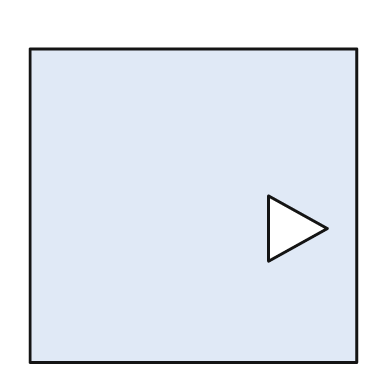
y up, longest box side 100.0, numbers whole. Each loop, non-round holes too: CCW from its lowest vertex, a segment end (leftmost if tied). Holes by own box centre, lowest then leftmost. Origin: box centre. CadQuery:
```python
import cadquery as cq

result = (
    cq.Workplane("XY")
    .moveTo(-50.0, -48.0)
    .lineTo(50.0, -48.0)
    .lineTo(50.0, 48.0)
    .lineTo(-50.0, 48.0)
    .close()
    .moveTo(23.0, -17.0)
    .lineTo(41.0, -7.0)
    .lineTo(23.0, 3.0)
    .close()
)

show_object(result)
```